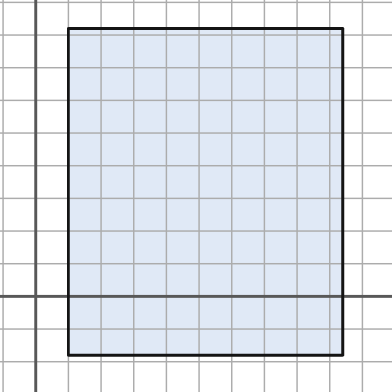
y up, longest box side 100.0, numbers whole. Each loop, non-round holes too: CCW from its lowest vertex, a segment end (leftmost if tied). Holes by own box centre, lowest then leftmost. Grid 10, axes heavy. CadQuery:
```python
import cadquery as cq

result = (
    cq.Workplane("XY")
    .moveTo(10.0, -18.0)
    .lineTo(94.0, -18.0)
    .lineTo(94.0, 82.0)
    .lineTo(10.0, 82.0)
    .close()
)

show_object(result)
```